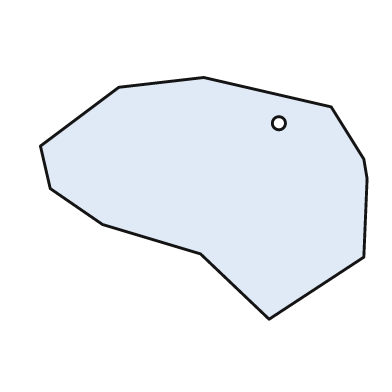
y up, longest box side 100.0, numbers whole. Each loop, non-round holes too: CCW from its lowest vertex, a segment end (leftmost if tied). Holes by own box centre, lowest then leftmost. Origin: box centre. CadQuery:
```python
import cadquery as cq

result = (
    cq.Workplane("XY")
    .moveTo(20.0, -37.0)
    .lineTo(49.0, -18.0)
    .lineTo(50.0, 6.0)
    .lineTo(49.0, 12.0)
    .lineTo(39.0, 28.0)
    .lineTo(0.0, 37.0)
    .lineTo(-26.0, 34.0)
    .lineTo(-50.0, 16.0)
    .lineTo(-47.0, 3.0)
    .lineTo(-31.0, -8.0)
    .lineTo(-1.0, -17.0)
    .close()
    .moveTo(23.0, 23.0)
    .circle(2.0)
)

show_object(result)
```